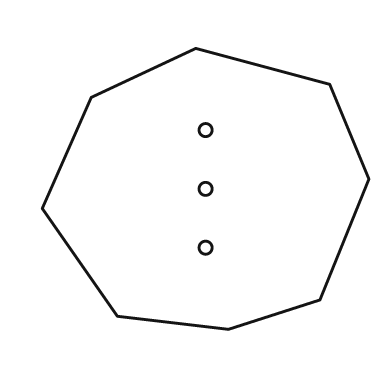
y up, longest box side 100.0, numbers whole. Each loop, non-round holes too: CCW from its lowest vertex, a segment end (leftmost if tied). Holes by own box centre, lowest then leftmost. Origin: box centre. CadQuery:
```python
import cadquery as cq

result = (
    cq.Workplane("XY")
    .moveTo(7.0, -43.0)
    .lineTo(35.0, -34.0)
    .lineTo(50.0, 3.0)
    .lineTo(38.0, 32.0)
    .lineTo(-3.0, 43.0)
    .lineTo(-35.0, 28.0)
    .lineTo(-50.0, -6.0)
    .lineTo(-27.0, -39.0)
    .close()
    .moveTo(0.0, -18.0)
    .circle(2.0)
    .moveTo(0.0, 0.0)
    .circle(2.0)
    .moveTo(0.0, 18.0)
    .circle(2.0)
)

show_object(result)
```